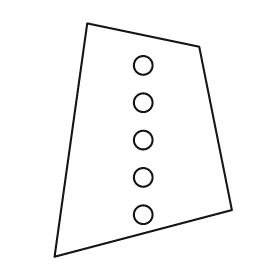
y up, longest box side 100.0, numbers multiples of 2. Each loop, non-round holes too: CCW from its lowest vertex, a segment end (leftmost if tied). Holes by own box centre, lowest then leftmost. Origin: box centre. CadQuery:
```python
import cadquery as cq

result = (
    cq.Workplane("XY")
    .moveTo(-38.0, -50.0)
    .lineTo(38.0, -30.0)
    .lineTo(24.0, 40.0)
    .lineTo(-24.0, 50.0)
    .close()
    .moveTo(0.0, -32.0)
    .circle(4.0)
    .moveTo(0.0, -16.0)
    .circle(4.0)
    .moveTo(0.0, 0.0)
    .circle(4.0)
    .moveTo(0.0, 16.0)
    .circle(4.0)
    .moveTo(0.0, 32.0)
    .circle(4.0)
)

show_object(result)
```